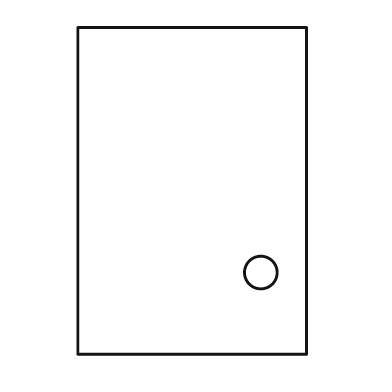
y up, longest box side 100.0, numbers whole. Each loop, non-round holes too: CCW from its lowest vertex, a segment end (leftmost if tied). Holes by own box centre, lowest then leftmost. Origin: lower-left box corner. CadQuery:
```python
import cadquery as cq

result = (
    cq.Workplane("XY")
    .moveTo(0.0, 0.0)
    .lineTo(70.0, 0.0)
    .lineTo(70.0, 100.0)
    .lineTo(0.0, 100.0)
    .close()
    .moveTo(56.0, 25.0)
    .circle(5.0)
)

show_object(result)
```